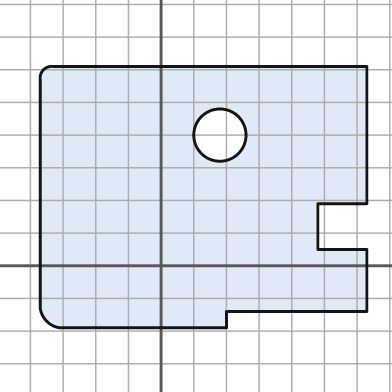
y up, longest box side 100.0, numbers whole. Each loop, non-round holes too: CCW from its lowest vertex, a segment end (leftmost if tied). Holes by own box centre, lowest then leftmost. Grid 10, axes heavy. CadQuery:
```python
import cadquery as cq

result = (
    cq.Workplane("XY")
    .moveTo(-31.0, -19.0)
    .lineTo(20.0, -19.0)
    .lineTo(20.0, -14.0)
    .lineTo(63.0, -14.0)
    .lineTo(63.0, 5.0)
    .lineTo(48.0, 5.0)
    .lineTo(48.0, 19.0)
    .lineTo(63.0, 19.0)
    .lineTo(63.0, 61.0)
    .lineTo(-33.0, 61.0)
    .threePointArc((-36.0, 60.0), (-37.0, 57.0))
    .lineTo(-37.0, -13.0)
    .threePointArc((-35.0, -17.0), (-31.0, -19.0))
    .close()
    .moveTo(18.0, 40.0)
    .circle(8.0)
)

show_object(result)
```